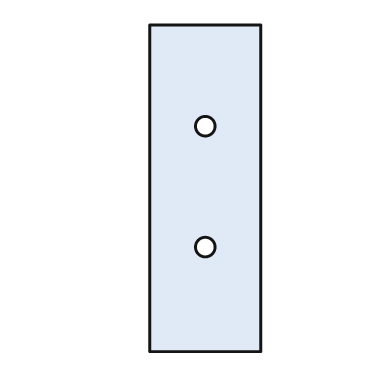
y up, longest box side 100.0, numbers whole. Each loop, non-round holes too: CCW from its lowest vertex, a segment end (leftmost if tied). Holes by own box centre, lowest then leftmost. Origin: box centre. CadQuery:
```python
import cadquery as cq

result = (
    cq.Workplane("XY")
    .moveTo(-17.0, -50.0)
    .lineTo(17.0, -50.0)
    .lineTo(17.0, 50.0)
    .lineTo(-17.0, 50.0)
    .close()
    .moveTo(0.0, -18.0)
    .circle(3.0)
    .moveTo(0.0, 19.0)
    .circle(3.0)
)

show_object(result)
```